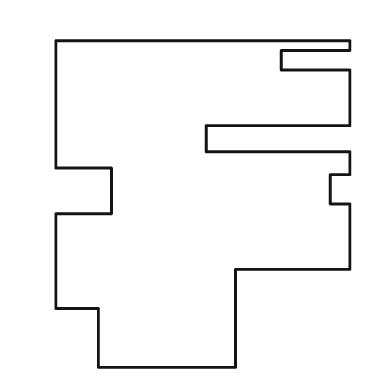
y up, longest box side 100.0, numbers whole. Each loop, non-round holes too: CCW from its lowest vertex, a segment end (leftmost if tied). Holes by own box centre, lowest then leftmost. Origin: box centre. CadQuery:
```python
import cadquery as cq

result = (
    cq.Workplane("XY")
    .moveTo(-32.0, -50.0)
    .lineTo(10.0, -50.0)
    .lineTo(10.0, -20.0)
    .lineTo(45.0, -20.0)
    .lineTo(45.0, 0.0)
    .lineTo(39.0, 0.0)
    .lineTo(39.0, 9.0)
    .lineTo(45.0, 9.0)
    .lineTo(45.0, 16.0)
    .lineTo(1.0, 16.0)
    .lineTo(1.0, 24.0)
    .lineTo(45.0, 24.0)
    .lineTo(45.0, 41.0)
    .lineTo(24.0, 41.0)
    .lineTo(24.0, 47.0)
    .lineTo(45.0, 47.0)
    .lineTo(45.0, 50.0)
    .lineTo(-45.0, 50.0)
    .lineTo(-45.0, 11.0)
    .lineTo(-28.0, 11.0)
    .lineTo(-28.0, -3.0)
    .lineTo(-45.0, -3.0)
    .lineTo(-45.0, -32.0)
    .lineTo(-32.0, -32.0)
    .close()
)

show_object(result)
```